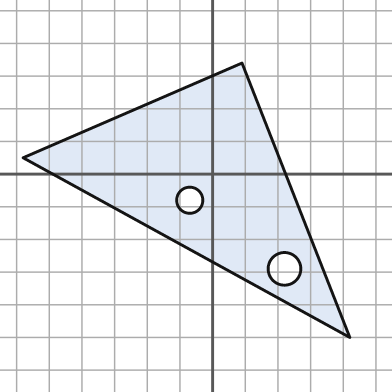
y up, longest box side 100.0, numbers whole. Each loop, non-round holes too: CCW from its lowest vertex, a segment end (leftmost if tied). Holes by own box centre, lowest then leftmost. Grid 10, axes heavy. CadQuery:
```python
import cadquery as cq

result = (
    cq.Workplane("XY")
    .moveTo(42.0, -50.0)
    .lineTo(9.0, 34.0)
    .lineTo(-58.0, 5.0)
    .close()
    .moveTo(22.0, -29.0)
    .circle(5.0)
    .moveTo(-7.0, -8.0)
    .circle(4.0)
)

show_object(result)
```